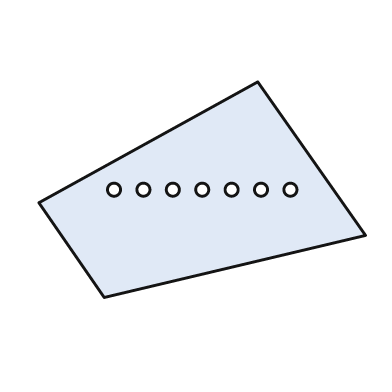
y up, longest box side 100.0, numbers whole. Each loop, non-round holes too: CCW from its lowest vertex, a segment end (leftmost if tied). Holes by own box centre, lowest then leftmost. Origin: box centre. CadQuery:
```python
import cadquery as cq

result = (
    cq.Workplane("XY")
    .moveTo(-30.0, -33.0)
    .lineTo(50.0, -14.0)
    .lineTo(17.0, 33.0)
    .lineTo(-50.0, -4.0)
    .close()
    .moveTo(-27.0, 0.0)
    .circle(2.0)
    .moveTo(-18.0, 0.0)
    .circle(2.0)
    .moveTo(-9.0, 0.0)
    .circle(2.0)
    .moveTo(0.0, 0.0)
    .circle(2.0)
    .moveTo(9.0, 0.0)
    .circle(2.0)
    .moveTo(18.0, 0.0)
    .circle(2.0)
    .moveTo(27.0, 0.0)
    .circle(2.0)
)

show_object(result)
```